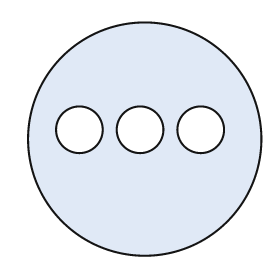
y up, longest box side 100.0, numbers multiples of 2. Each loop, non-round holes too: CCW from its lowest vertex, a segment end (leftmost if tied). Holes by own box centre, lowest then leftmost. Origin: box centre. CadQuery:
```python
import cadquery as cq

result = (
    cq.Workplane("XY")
    .moveTo(0.0, 0.0)
    .circle(50.0)
    .moveTo(-28.0, 4.0)
    .circle(10.0)
    .moveTo(-2.0, 4.0)
    .circle(10.0)
    .moveTo(24.0, 4.0)
    .circle(10.0)
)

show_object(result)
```